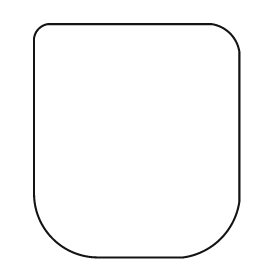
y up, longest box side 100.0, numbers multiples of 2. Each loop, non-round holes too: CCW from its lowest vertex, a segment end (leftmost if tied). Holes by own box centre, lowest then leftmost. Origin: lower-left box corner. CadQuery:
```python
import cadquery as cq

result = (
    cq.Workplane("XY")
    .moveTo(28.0, 0.0)
    .lineTo(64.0, 0.0)
    .threePointArc((80.0, 8.0), (88.0, 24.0))
    .lineTo(88.0, 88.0)
    .threePointArc((84.0, 96.0), (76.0, 100.0))
    .lineTo(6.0, 100.0)
    .threePointArc((2.0, 98.0), (0.0, 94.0))
    .lineTo(0.0, 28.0)
    .threePointArc((8.0, 8.0), (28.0, 0.0))
    .close()
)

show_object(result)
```